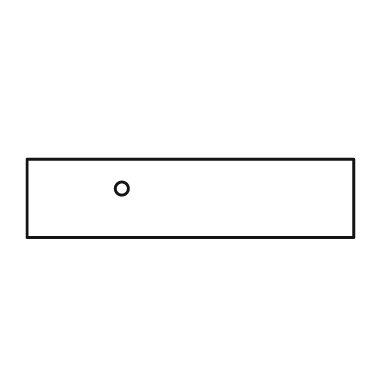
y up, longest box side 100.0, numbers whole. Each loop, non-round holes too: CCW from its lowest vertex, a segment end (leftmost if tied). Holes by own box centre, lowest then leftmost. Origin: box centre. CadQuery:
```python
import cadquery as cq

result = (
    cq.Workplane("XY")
    .moveTo(-50.0, -12.0)
    .lineTo(50.0, -12.0)
    .lineTo(50.0, 12.0)
    .lineTo(-50.0, 12.0)
    .close()
    .moveTo(-21.0, 3.0)
    .circle(2.0)
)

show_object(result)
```